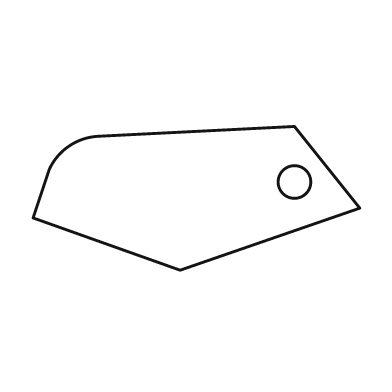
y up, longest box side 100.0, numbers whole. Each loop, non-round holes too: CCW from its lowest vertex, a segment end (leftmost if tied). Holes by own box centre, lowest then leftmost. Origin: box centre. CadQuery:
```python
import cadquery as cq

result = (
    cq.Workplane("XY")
    .moveTo(-5.0, -22.0)
    .lineTo(50.0, -3.0)
    .lineTo(30.0, 22.0)
    .lineTo(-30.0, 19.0)
    .threePointArc((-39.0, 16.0), (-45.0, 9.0))
    .lineTo(-50.0, -6.0)
    .close()
    .moveTo(30.0, 5.0)
    .circle(5.0)
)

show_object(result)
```